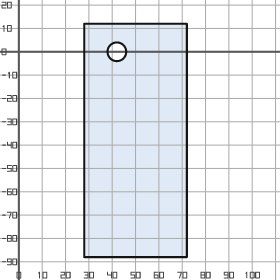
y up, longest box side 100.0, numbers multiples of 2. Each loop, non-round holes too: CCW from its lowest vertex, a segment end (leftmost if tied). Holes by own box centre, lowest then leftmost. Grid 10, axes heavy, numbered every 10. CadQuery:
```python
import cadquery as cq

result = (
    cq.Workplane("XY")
    .moveTo(28.0, -88.0)
    .lineTo(72.0, -88.0)
    .lineTo(72.0, 12.0)
    .lineTo(28.0, 12.0)
    .close()
    .moveTo(42.0, 0.0)
    .circle(4.0)
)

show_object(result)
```